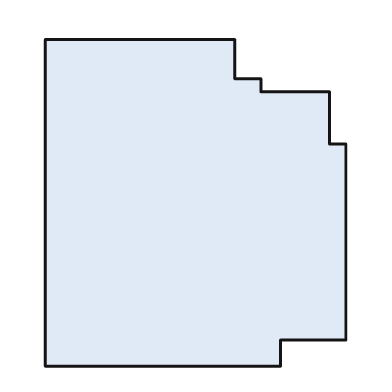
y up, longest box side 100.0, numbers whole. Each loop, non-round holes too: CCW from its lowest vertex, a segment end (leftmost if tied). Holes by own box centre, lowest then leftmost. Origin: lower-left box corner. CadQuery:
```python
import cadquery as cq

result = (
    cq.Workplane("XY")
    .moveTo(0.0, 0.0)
    .lineTo(72.0, 0.0)
    .lineTo(72.0, 8.0)
    .lineTo(92.0, 8.0)
    .lineTo(92.0, 68.0)
    .lineTo(87.0, 68.0)
    .lineTo(87.0, 84.0)
    .lineTo(66.0, 84.0)
    .lineTo(66.0, 88.0)
    .lineTo(58.0, 88.0)
    .lineTo(58.0, 100.0)
    .lineTo(0.0, 100.0)
    .close()
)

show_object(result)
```